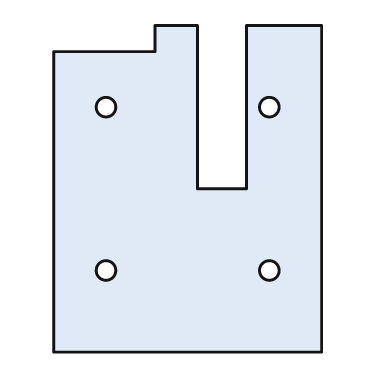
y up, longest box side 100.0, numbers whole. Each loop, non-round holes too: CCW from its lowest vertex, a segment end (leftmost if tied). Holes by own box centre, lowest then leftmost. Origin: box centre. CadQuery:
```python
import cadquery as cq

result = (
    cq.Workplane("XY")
    .moveTo(-41.0, -50.0)
    .lineTo(41.0, -50.0)
    .lineTo(41.0, 50.0)
    .lineTo(18.0, 50.0)
    .lineTo(18.0, 0.0)
    .lineTo(3.0, 0.0)
    .lineTo(3.0, 50.0)
    .lineTo(-10.0, 50.0)
    .lineTo(-10.0, 42.0)
    .lineTo(-41.0, 42.0)
    .close()
    .moveTo(-25.0, -25.0)
    .circle(3.0)
    .moveTo(25.0, -25.0)
    .circle(3.0)
    .moveTo(-25.0, 25.0)
    .circle(3.0)
    .moveTo(25.0, 25.0)
    .circle(3.0)
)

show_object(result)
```